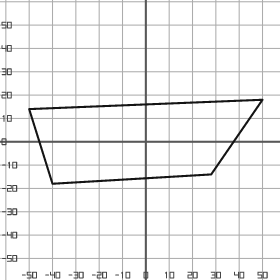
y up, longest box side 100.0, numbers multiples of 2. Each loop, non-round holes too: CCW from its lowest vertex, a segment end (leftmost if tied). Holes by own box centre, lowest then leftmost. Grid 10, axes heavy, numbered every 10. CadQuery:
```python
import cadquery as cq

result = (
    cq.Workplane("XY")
    .moveTo(-40.0, -18.0)
    .lineTo(28.0, -14.0)
    .lineTo(50.0, 18.0)
    .lineTo(-50.0, 14.0)
    .close()
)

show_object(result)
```